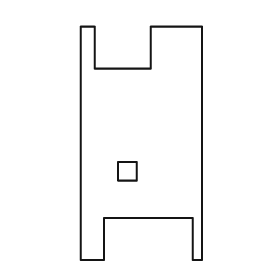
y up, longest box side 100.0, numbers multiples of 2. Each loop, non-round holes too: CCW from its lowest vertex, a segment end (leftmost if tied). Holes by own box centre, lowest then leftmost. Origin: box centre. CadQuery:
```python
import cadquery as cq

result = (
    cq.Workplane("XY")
    .moveTo(-26.0, -50.0)
    .lineTo(-16.0, -50.0)
    .lineTo(-16.0, -32.0)
    .lineTo(22.0, -32.0)
    .lineTo(22.0, -50.0)
    .lineTo(26.0, -50.0)
    .lineTo(26.0, 50.0)
    .lineTo(4.0, 50.0)
    .lineTo(4.0, 32.0)
    .lineTo(-20.0, 32.0)
    .lineTo(-20.0, 50.0)
    .lineTo(-26.0, 50.0)
    .close()
    .moveTo(-10.0, -16.0)
    .lineTo(-2.0, -16.0)
    .lineTo(-2.0, -8.0)
    .lineTo(-10.0, -8.0)
    .close()
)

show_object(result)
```